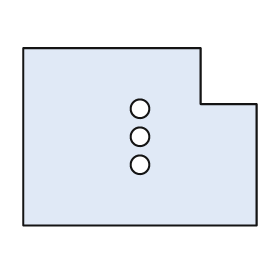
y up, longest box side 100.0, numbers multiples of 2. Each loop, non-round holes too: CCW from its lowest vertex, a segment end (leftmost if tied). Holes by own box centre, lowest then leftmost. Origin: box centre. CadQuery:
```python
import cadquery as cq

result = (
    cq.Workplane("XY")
    .moveTo(-50.0, -38.0)
    .lineTo(50.0, -38.0)
    .lineTo(50.0, 14.0)
    .lineTo(26.0, 14.0)
    .lineTo(26.0, 38.0)
    .lineTo(-50.0, 38.0)
    .close()
    .moveTo(0.0, -12.0)
    .circle(4.0)
    .moveTo(0.0, 0.0)
    .circle(4.0)
    .moveTo(0.0, 12.0)
    .circle(4.0)
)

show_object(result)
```